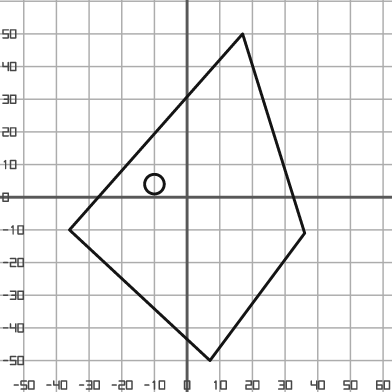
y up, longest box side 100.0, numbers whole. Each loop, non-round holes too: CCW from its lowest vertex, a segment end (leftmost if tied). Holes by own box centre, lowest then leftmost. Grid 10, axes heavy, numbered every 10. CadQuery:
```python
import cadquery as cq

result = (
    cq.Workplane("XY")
    .moveTo(7.0, -50.0)
    .lineTo(36.0, -11.0)
    .lineTo(17.0, 50.0)
    .lineTo(-36.0, -10.0)
    .close()
    .moveTo(-10.0, 4.0)
    .circle(3.0)
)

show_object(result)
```